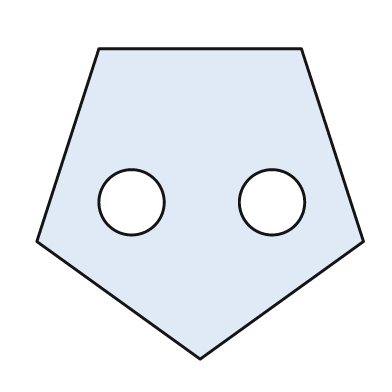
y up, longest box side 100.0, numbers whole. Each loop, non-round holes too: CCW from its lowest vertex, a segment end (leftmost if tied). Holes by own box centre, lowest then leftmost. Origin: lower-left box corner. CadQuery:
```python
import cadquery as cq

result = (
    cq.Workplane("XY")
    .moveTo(50.0, 0.0)
    .lineTo(100.0, 36.0)
    .lineTo(81.0, 95.0)
    .lineTo(19.0, 95.0)
    .lineTo(0.0, 36.0)
    .close()
    .moveTo(29.0, 48.0)
    .circle(10.0)
    .moveTo(72.0, 48.0)
    .circle(10.0)
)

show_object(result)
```